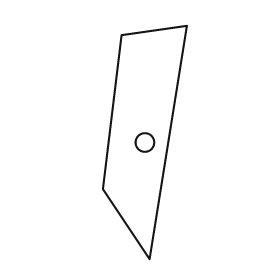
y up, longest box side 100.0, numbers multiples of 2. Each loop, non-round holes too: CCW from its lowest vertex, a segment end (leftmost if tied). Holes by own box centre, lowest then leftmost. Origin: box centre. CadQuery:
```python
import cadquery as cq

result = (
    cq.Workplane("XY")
    .moveTo(2.0, -50.0)
    .lineTo(18.0, 50.0)
    .lineTo(-10.0, 46.0)
    .lineTo(-18.0, -20.0)
    .close()
    .moveTo(0.0, 0.0)
    .circle(4.0)
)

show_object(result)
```